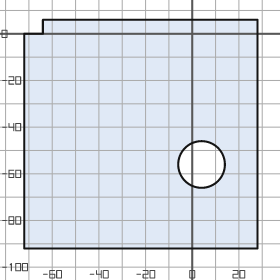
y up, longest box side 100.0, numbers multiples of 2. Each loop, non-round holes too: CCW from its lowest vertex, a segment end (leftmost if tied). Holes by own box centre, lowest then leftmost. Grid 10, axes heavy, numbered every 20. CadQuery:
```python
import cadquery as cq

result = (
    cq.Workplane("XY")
    .moveTo(-72.0, -92.0)
    .lineTo(28.0, -92.0)
    .lineTo(28.0, 6.0)
    .lineTo(-64.0, 6.0)
    .lineTo(-64.0, 0.0)
    .lineTo(-72.0, 0.0)
    .close()
    .moveTo(4.0, -56.0)
    .circle(10.0)
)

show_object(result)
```